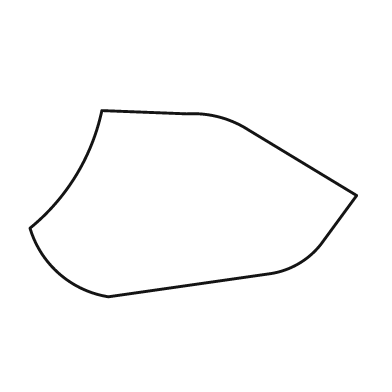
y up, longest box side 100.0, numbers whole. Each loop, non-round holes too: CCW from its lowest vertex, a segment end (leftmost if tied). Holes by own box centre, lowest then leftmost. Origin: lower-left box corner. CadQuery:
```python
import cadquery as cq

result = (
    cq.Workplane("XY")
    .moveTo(24.0, 0.0)
    .lineTo(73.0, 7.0)
    .threePointArc((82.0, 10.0), (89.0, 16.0))
    .lineTo(100.0, 31.0)
    .lineTo(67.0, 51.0)
    .threePointArc((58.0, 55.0), (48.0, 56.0))
    .lineTo(22.0, 57.0)
    .threePointArc((14.0, 37.0), (0.0, 21.0))
    .threePointArc((9.0, 7.0), (24.0, 0.0))
    .close()
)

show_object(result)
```